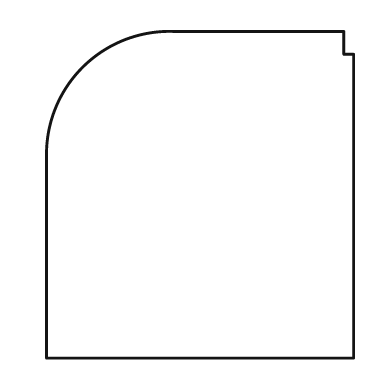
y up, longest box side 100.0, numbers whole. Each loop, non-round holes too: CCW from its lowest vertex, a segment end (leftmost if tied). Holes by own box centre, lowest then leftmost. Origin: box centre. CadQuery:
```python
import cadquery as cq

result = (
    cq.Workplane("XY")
    .moveTo(-47.0, -50.0)
    .lineTo(47.0, -50.0)
    .lineTo(47.0, 43.0)
    .lineTo(44.0, 43.0)
    .lineTo(44.0, 50.0)
    .lineTo(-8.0, 50.0)
    .threePointArc((-36.0, 39.0), (-47.0, 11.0))
    .close()
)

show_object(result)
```